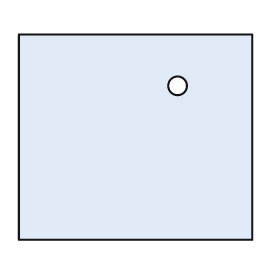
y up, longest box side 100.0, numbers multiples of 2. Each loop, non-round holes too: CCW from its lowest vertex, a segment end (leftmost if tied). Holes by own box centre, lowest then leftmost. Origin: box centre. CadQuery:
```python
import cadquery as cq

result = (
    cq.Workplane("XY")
    .moveTo(-50.0, -44.0)
    .lineTo(50.0, -44.0)
    .lineTo(50.0, 44.0)
    .lineTo(-50.0, 44.0)
    .close()
    .moveTo(18.0, 22.0)
    .circle(4.0)
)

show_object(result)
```